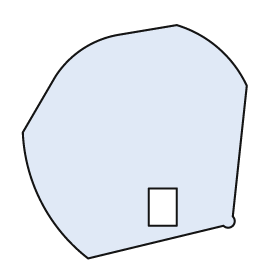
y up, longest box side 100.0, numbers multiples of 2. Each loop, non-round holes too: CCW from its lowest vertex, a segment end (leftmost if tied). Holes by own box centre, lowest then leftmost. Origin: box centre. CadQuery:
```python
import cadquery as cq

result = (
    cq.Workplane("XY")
    .moveTo(-20.0, -50.0)
    .lineTo(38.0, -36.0)
    .threePointArc((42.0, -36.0), (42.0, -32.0))
    .lineTo(48.0, 24.0)
    .threePointArc((36.0, 40.0), (18.0, 50.0))
    .lineTo(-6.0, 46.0)
    .threePointArc((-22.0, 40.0), (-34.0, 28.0))
    .lineTo(-48.0, 4.0)
    .threePointArc((-40.0, -26.0), (-20.0, -50.0))
    .close()
    .moveTo(6.0, -36.0)
    .lineTo(18.0, -36.0)
    .lineTo(18.0, -20.0)
    .lineTo(6.0, -20.0)
    .close()
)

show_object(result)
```